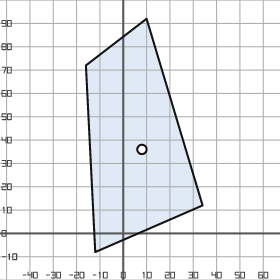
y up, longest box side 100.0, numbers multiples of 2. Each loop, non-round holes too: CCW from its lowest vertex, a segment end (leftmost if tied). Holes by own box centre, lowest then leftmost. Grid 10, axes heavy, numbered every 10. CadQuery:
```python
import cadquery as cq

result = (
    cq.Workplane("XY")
    .moveTo(-12.0, -8.0)
    .lineTo(34.0, 12.0)
    .lineTo(10.0, 92.0)
    .lineTo(-16.0, 72.0)
    .close()
    .moveTo(8.0, 36.0)
    .circle(2.0)
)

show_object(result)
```